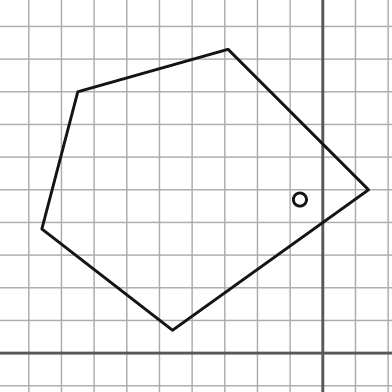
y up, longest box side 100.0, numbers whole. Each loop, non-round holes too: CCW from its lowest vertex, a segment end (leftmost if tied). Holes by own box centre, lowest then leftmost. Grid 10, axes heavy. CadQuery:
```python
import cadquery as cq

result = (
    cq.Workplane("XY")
    .moveTo(-46.0, 7.0)
    .lineTo(14.0, 50.0)
    .lineTo(-29.0, 93.0)
    .lineTo(-75.0, 80.0)
    .lineTo(-86.0, 38.0)
    .close()
    .moveTo(-7.0, 47.0)
    .circle(2.0)
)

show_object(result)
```